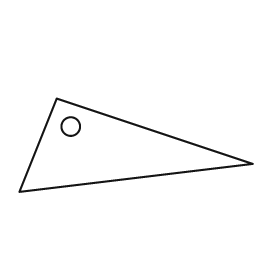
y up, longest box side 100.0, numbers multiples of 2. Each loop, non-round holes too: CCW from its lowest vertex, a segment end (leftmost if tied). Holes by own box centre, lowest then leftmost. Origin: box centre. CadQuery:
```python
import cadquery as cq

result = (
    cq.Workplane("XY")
    .moveTo(-50.0, -20.0)
    .lineTo(50.0, -8.0)
    .lineTo(-34.0, 20.0)
    .close()
    .moveTo(-28.0, 8.0)
    .circle(4.0)
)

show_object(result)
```